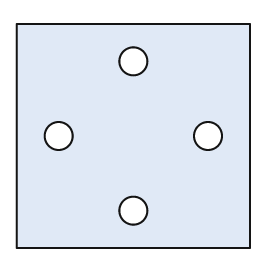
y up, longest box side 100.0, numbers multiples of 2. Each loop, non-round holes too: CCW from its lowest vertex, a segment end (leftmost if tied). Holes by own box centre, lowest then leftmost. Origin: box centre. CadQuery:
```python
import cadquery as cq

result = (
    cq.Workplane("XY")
    .moveTo(-50.0, -48.0)
    .lineTo(50.0, -48.0)
    .lineTo(50.0, 48.0)
    .lineTo(-50.0, 48.0)
    .close()
    .moveTo(0.0, -32.0)
    .circle(6.0)
    .moveTo(-32.0, 0.0)
    .circle(6.0)
    .moveTo(32.0, 0.0)
    .circle(6.0)
    .moveTo(0.0, 32.0)
    .circle(6.0)
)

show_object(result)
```